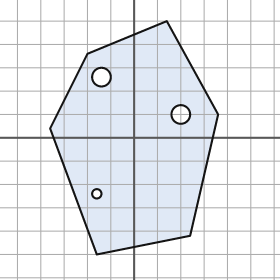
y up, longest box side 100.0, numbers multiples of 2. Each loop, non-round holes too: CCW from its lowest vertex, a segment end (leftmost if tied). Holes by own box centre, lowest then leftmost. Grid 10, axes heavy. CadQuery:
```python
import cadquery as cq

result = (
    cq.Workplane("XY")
    .moveTo(-16.0, -50.0)
    .lineTo(24.0, -42.0)
    .lineTo(36.0, 10.0)
    .lineTo(14.0, 50.0)
    .lineTo(-20.0, 36.0)
    .lineTo(-36.0, 4.0)
    .close()
    .moveTo(-16.0, -24.0)
    .circle(2.0)
    .moveTo(20.0, 10.0)
    .circle(4.0)
    .moveTo(-14.0, 26.0)
    .circle(4.0)
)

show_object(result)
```